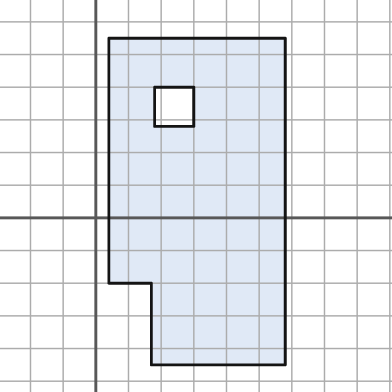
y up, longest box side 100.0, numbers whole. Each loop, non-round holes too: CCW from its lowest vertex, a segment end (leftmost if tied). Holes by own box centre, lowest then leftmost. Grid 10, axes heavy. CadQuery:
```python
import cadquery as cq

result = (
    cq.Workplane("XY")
    .moveTo(17.0, -45.0)
    .lineTo(58.0, -45.0)
    .lineTo(58.0, 55.0)
    .lineTo(4.0, 55.0)
    .lineTo(4.0, -20.0)
    .lineTo(17.0, -20.0)
    .close()
    .moveTo(18.0, 28.0)
    .lineTo(30.0, 28.0)
    .lineTo(30.0, 40.0)
    .lineTo(18.0, 40.0)
    .close()
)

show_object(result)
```